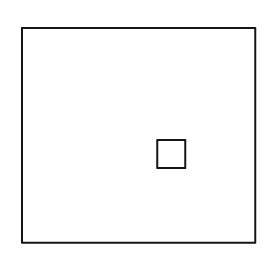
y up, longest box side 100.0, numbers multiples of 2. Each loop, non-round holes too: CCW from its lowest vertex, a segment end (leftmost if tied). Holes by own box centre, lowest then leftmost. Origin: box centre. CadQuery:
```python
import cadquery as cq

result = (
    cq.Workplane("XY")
    .moveTo(-50.0, -46.0)
    .lineTo(50.0, -46.0)
    .lineTo(50.0, 46.0)
    .lineTo(-50.0, 46.0)
    .close()
    .moveTo(8.0, -14.0)
    .lineTo(20.0, -14.0)
    .lineTo(20.0, -2.0)
    .lineTo(8.0, -2.0)
    .close()
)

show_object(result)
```